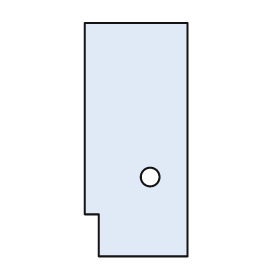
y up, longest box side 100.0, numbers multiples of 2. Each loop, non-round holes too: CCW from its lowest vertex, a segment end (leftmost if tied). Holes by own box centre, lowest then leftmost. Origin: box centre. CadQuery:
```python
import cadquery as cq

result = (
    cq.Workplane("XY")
    .moveTo(-16.0, -50.0)
    .lineTo(22.0, -50.0)
    .lineTo(22.0, 50.0)
    .lineTo(-22.0, 50.0)
    .lineTo(-22.0, -32.0)
    .lineTo(-16.0, -32.0)
    .close()
    .moveTo(6.0, -16.0)
    .circle(4.0)
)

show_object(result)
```